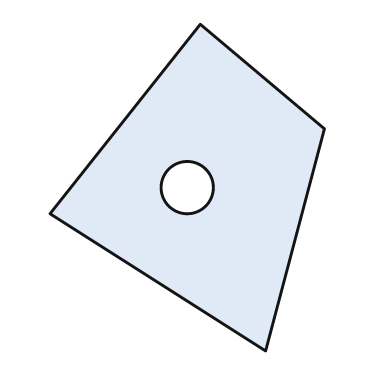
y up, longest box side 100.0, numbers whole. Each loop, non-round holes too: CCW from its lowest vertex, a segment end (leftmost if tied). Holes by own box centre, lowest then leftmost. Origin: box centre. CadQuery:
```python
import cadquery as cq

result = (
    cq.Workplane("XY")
    .moveTo(24.0, -50.0)
    .lineTo(42.0, 18.0)
    .lineTo(4.0, 50.0)
    .lineTo(-42.0, -8.0)
    .close()
    .moveTo(0.0, 0.0)
    .circle(8.0)
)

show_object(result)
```